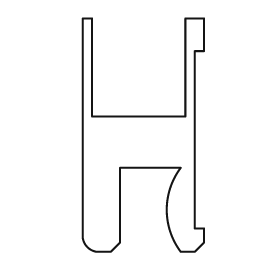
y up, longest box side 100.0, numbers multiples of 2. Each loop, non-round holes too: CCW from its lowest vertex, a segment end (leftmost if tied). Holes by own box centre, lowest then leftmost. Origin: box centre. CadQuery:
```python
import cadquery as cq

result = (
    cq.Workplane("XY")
    .moveTo(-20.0, -50.0)
    .lineTo(-14.0, -50.0)
    .lineTo(-10.0, -46.0)
    .lineTo(-10.0, -14.0)
    .lineTo(16.0, -14.0)
    .threePointArc((10.0, -32.0), (16.0, -50.0))
    .lineTo(22.0, -50.0)
    .lineTo(26.0, -46.0)
    .lineTo(26.0, -40.0)
    .lineTo(22.0, -40.0)
    .lineTo(22.0, 36.0)
    .lineTo(26.0, 36.0)
    .lineTo(26.0, 50.0)
    .lineTo(18.0, 50.0)
    .lineTo(18.0, 8.0)
    .lineTo(-22.0, 8.0)
    .lineTo(-22.0, 50.0)
    .lineTo(-26.0, 50.0)
    .lineTo(-26.0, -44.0)
    .threePointArc((-24.0, -48.0), (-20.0, -50.0))
    .close()
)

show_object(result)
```